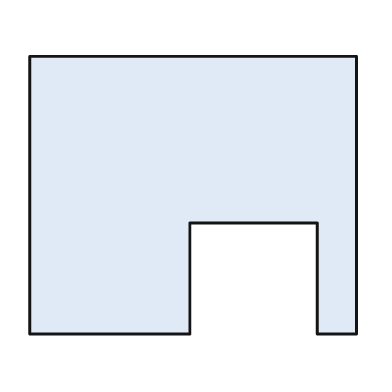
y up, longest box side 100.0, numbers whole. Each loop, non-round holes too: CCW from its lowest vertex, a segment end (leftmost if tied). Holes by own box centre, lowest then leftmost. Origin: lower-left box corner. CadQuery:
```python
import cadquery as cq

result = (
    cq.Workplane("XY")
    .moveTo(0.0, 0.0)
    .lineTo(49.0, 0.0)
    .lineTo(49.0, 34.0)
    .lineTo(88.0, 34.0)
    .lineTo(88.0, 0.0)
    .lineTo(100.0, 0.0)
    .lineTo(100.0, 85.0)
    .lineTo(0.0, 85.0)
    .close()
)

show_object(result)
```